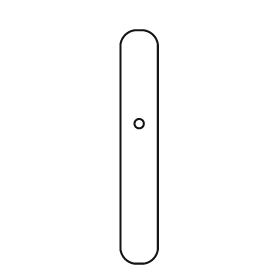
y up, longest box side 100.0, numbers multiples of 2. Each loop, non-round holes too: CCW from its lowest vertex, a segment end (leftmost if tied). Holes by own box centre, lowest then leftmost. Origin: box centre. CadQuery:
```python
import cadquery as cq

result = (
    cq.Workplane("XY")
    .moveTo(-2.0, -50.0)
    .lineTo(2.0, -50.0)
    .threePointArc((6.0, -48.0), (8.0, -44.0))
    .lineTo(8.0, 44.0)
    .threePointArc((6.0, 48.0), (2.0, 50.0))
    .lineTo(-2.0, 50.0)
    .threePointArc((-6.0, 48.0), (-8.0, 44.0))
    .lineTo(-8.0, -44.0)
    .threePointArc((-6.0, -48.0), (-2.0, -50.0))
    .close()
    .moveTo(0.0, 10.0)
    .circle(2.0)
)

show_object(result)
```